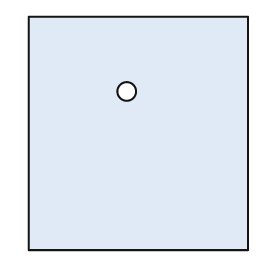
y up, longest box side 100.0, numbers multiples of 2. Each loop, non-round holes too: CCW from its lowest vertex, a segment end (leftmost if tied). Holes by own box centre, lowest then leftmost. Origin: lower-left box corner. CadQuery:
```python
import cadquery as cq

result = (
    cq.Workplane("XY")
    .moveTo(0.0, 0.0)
    .lineTo(94.0, 0.0)
    .lineTo(94.0, 100.0)
    .lineTo(0.0, 100.0)
    .close()
    .moveTo(42.0, 68.0)
    .circle(4.0)
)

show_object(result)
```